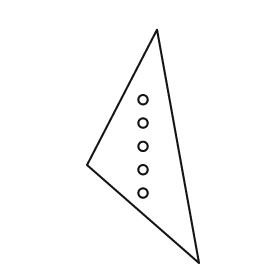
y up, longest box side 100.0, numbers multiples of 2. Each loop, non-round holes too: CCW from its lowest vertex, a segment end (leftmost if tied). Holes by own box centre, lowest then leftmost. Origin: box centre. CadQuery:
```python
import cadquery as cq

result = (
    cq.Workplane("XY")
    .moveTo(24.0, -50.0)
    .lineTo(6.0, 50.0)
    .lineTo(-24.0, -8.0)
    .close()
    .moveTo(0.0, -20.0)
    .circle(2.0)
    .moveTo(0.0, -10.0)
    .circle(2.0)
    .moveTo(0.0, 0.0)
    .circle(2.0)
    .moveTo(0.0, 10.0)
    .circle(2.0)
    .moveTo(0.0, 20.0)
    .circle(2.0)
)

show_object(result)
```